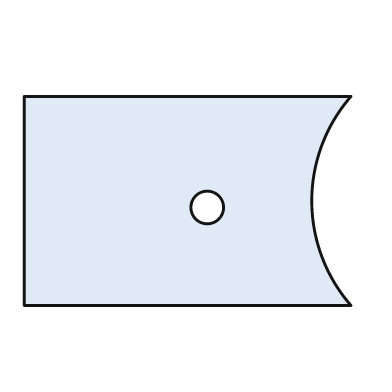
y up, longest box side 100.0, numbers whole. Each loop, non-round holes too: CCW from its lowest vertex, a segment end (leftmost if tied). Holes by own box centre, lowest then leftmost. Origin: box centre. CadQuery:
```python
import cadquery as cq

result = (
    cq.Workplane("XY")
    .moveTo(-50.0, -32.0)
    .lineTo(50.0, -32.0)
    .threePointArc((38.0, 0.0), (50.0, 32.0))
    .lineTo(-50.0, 32.0)
    .close()
    .moveTo(6.0, -2.0)
    .circle(5.0)
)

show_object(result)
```